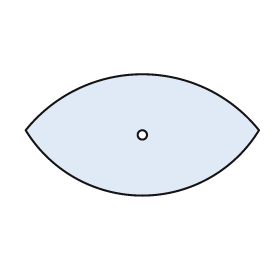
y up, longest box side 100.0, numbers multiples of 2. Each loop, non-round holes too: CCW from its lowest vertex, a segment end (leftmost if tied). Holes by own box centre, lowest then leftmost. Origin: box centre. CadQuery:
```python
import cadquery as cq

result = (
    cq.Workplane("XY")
    .moveTo(-50.0, 2.0)
    .threePointArc((0.0, -26.0), (50.0, 2.0))
    .threePointArc((0.0, 26.0), (-50.0, 2.0))
    .close()
    .moveTo(0.0, 0.0)
    .circle(2.0)
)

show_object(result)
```